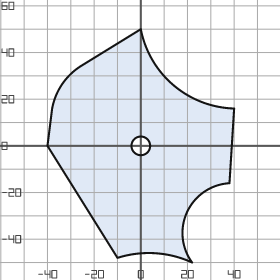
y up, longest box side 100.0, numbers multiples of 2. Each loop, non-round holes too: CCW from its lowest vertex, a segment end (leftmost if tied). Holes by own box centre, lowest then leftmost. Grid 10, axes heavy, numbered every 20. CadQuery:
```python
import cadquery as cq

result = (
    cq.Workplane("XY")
    .moveTo(22.0, -50.0)
    .threePointArc((20.0, -28.0), (38.0, -16.0))
    .lineTo(40.0, 16.0)
    .threePointArc((14.0, 26.0), (0.0, 50.0))
    .lineTo(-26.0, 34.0)
    .threePointArc((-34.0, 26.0), (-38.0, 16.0))
    .lineTo(-40.0, 0.0)
    .lineTo(-10.0, -48.0)
    .threePointArc((6.0, -46.0), (22.0, -50.0))
    .close()
    .moveTo(0.0, 0.0)
    .circle(4.0)
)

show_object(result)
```